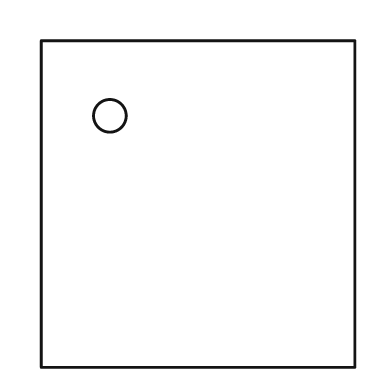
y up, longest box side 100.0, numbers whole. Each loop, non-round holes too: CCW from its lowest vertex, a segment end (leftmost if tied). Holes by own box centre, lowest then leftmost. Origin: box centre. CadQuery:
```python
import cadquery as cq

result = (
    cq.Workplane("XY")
    .moveTo(-48.0, -50.0)
    .lineTo(48.0, -50.0)
    .lineTo(48.0, 50.0)
    .lineTo(-48.0, 50.0)
    .close()
    .moveTo(-27.0, 27.0)
    .circle(5.0)
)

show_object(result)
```